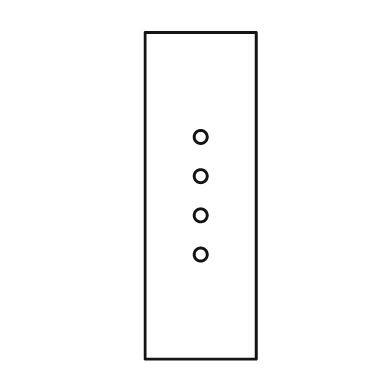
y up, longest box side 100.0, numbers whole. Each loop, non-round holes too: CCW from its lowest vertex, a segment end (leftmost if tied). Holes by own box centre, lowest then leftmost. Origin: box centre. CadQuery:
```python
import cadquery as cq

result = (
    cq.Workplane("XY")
    .moveTo(-17.0, -50.0)
    .lineTo(17.0, -50.0)
    .lineTo(17.0, 50.0)
    .lineTo(-17.0, 50.0)
    .close()
    .moveTo(0.0, -18.0)
    .circle(2.0)
    .moveTo(0.0, -6.0)
    .circle(2.0)
    .moveTo(0.0, 6.0)
    .circle(2.0)
    .moveTo(0.0, 18.0)
    .circle(2.0)
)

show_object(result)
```